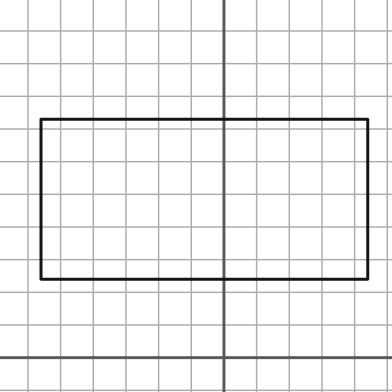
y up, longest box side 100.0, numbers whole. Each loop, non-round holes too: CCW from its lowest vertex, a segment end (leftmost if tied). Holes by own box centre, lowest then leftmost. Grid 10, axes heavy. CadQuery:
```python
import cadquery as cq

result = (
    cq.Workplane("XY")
    .moveTo(-56.0, 24.0)
    .lineTo(44.0, 24.0)
    .lineTo(44.0, 73.0)
    .lineTo(-56.0, 73.0)
    .close()
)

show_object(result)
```